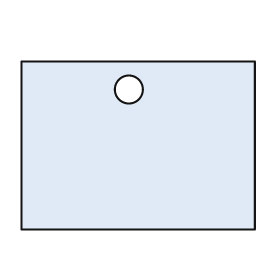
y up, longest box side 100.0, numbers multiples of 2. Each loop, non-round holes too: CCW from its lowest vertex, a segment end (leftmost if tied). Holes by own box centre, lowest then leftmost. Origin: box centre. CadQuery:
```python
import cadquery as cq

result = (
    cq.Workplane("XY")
    .moveTo(-50.0, -36.0)
    .lineTo(50.0, -36.0)
    .lineTo(50.0, 36.0)
    .lineTo(-50.0, 36.0)
    .close()
    .moveTo(-4.0, 24.0)
    .circle(6.0)
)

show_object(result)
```